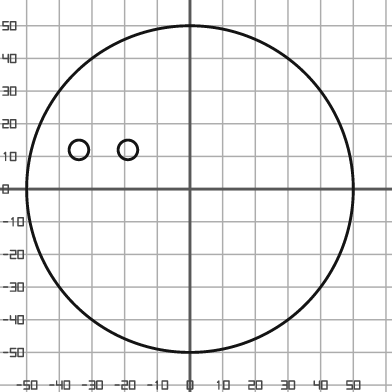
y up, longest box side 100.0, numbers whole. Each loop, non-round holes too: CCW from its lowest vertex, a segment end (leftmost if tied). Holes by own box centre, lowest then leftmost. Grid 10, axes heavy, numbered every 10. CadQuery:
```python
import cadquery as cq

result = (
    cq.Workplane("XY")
    .moveTo(0.0, 0.0)
    .circle(50.0)
    .moveTo(-34.0, 12.0)
    .circle(3.0)
    .moveTo(-19.0, 12.0)
    .circle(3.0)
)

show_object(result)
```